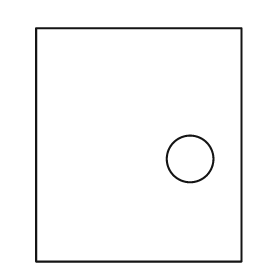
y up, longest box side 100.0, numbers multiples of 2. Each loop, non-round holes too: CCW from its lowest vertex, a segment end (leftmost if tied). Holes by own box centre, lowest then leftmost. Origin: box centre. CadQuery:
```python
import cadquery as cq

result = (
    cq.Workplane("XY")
    .moveTo(-44.0, -50.0)
    .lineTo(44.0, -50.0)
    .lineTo(44.0, 50.0)
    .lineTo(-44.0, 50.0)
    .close()
    .moveTo(22.0, -6.0)
    .circle(10.0)
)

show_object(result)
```